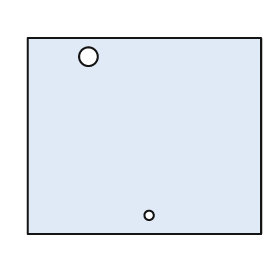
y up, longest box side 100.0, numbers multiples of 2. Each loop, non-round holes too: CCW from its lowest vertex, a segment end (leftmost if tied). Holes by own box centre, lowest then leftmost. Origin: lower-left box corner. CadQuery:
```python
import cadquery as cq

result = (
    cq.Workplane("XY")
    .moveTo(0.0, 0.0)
    .lineTo(100.0, 0.0)
    .lineTo(100.0, 84.0)
    .lineTo(0.0, 84.0)
    .close()
    .moveTo(52.0, 8.0)
    .circle(2.0)
    .moveTo(26.0, 76.0)
    .circle(4.0)
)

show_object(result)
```